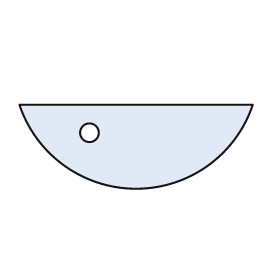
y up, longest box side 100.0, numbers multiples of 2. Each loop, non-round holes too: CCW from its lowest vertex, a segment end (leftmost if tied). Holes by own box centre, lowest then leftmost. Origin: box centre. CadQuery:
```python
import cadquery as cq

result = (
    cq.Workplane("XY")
    .moveTo(-50.0, 18.0)
    .threePointArc((0.0, -18.0), (50.0, 18.0))
    .close()
    .moveTo(-20.0, 6.0)
    .circle(4.0)
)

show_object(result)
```